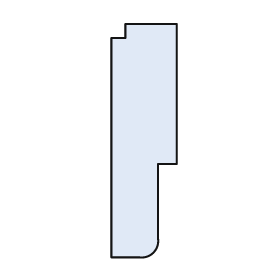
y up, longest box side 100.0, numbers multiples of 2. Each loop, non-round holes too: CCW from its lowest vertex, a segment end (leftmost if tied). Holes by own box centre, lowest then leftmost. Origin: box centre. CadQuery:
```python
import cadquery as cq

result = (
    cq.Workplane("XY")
    .moveTo(-14.0, -50.0)
    .lineTo(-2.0, -50.0)
    .threePointArc((4.0, -48.0), (6.0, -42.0))
    .lineTo(6.0, -10.0)
    .lineTo(14.0, -10.0)
    .lineTo(14.0, 50.0)
    .lineTo(-8.0, 50.0)
    .lineTo(-8.0, 44.0)
    .lineTo(-14.0, 44.0)
    .close()
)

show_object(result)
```